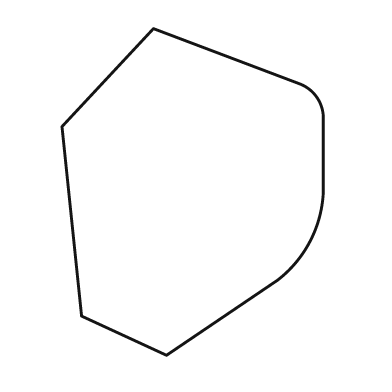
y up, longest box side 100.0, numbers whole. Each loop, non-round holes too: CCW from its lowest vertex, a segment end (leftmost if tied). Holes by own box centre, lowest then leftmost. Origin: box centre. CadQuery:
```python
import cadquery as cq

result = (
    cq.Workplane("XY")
    .moveTo(-8.0, -50.0)
    .lineTo(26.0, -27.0)
    .threePointArc((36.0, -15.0), (40.0, 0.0))
    .lineTo(40.0, 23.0)
    .threePointArc((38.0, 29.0), (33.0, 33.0))
    .lineTo(-12.0, 50.0)
    .lineTo(-40.0, 20.0)
    .lineTo(-34.0, -38.0)
    .close()
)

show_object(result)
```